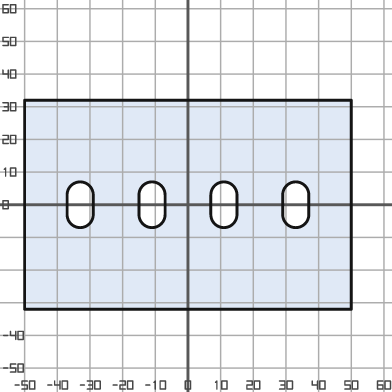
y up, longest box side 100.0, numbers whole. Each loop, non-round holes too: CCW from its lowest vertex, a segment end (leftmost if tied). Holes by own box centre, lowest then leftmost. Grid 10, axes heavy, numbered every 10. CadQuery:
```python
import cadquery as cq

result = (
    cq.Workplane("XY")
    .moveTo(-50.0, -32.0)
    .lineTo(50.0, -32.0)
    .lineTo(50.0, 32.0)
    .lineTo(-50.0, 32.0)
    .close()
    .moveTo(-37.0, -3.0)
    .threePointArc((-33.0, -7.0), (-29.0, -3.0))
    .lineTo(-29.0, 3.0)
    .threePointArc((-33.0, 7.0), (-37.0, 3.0))
    .close()
    .moveTo(-15.0, -3.0)
    .threePointArc((-11.0, -7.0), (-7.0, -3.0))
    .lineTo(-7.0, 3.0)
    .threePointArc((-11.0, 7.0), (-15.0, 3.0))
    .close()
    .moveTo(7.0, -3.0)
    .threePointArc((11.0, -7.0), (15.0, -3.0))
    .lineTo(15.0, 3.0)
    .threePointArc((11.0, 7.0), (7.0, 3.0))
    .close()
    .moveTo(29.0, -3.0)
    .threePointArc((33.0, -7.0), (37.0, -3.0))
    .lineTo(37.0, 3.0)
    .threePointArc((33.0, 7.0), (29.0, 3.0))
    .close()
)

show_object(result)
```